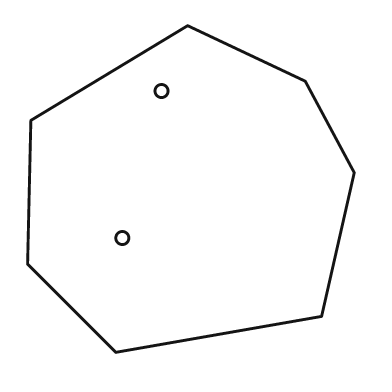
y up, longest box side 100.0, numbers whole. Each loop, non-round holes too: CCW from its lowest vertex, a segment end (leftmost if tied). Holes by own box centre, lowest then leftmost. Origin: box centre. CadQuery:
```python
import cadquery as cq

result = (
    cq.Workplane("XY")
    .moveTo(-23.0, -50.0)
    .lineTo(40.0, -39.0)
    .lineTo(50.0, 5.0)
    .lineTo(35.0, 33.0)
    .lineTo(-1.0, 50.0)
    .lineTo(-49.0, 21.0)
    .lineTo(-50.0, -23.0)
    .close()
    .moveTo(-21.0, -15.0)
    .circle(2.0)
    .moveTo(-9.0, 30.0)
    .circle(2.0)
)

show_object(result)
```